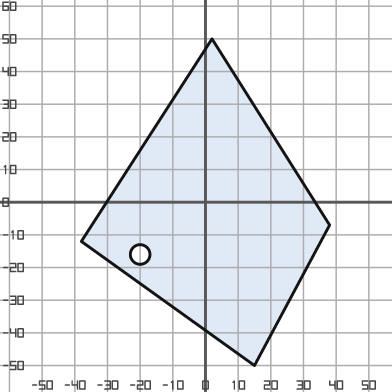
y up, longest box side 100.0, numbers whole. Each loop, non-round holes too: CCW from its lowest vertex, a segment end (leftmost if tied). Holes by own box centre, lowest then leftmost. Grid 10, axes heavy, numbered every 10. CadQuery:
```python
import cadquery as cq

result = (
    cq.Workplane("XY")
    .moveTo(15.0, -50.0)
    .lineTo(38.0, -7.0)
    .lineTo(2.0, 50.0)
    .lineTo(-38.0, -12.0)
    .close()
    .moveTo(-20.0, -16.0)
    .circle(3.0)
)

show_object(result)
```